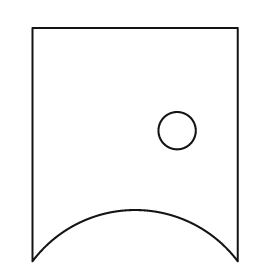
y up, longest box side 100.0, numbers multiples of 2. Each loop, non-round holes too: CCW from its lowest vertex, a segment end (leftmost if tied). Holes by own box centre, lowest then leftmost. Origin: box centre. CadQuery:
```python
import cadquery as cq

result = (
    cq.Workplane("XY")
    .moveTo(-44.0, -50.0)
    .threePointArc((0.0, -28.0), (44.0, -50.0))
    .lineTo(44.0, 50.0)
    .lineTo(-44.0, 50.0)
    .close()
    .moveTo(18.0, 6.0)
    .circle(8.0)
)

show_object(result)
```